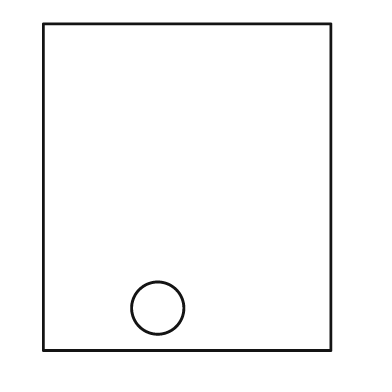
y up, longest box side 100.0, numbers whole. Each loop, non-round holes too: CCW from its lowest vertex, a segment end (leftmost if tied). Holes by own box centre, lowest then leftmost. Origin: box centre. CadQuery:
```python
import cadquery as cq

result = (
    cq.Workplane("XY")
    .moveTo(-44.0, -50.0)
    .lineTo(44.0, -50.0)
    .lineTo(44.0, 50.0)
    .lineTo(-44.0, 50.0)
    .close()
    .moveTo(-9.0, -37.0)
    .circle(8.0)
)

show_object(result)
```